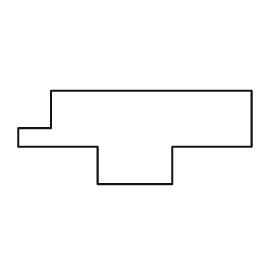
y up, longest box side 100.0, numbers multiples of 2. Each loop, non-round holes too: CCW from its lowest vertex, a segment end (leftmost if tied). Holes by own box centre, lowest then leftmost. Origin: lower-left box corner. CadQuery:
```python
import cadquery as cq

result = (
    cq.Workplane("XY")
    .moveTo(34.0, 0.0)
    .lineTo(66.0, 0.0)
    .lineTo(66.0, 16.0)
    .lineTo(100.0, 16.0)
    .lineTo(100.0, 40.0)
    .lineTo(14.0, 40.0)
    .lineTo(14.0, 24.0)
    .lineTo(0.0, 24.0)
    .lineTo(0.0, 16.0)
    .lineTo(34.0, 16.0)
    .close()
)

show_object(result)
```